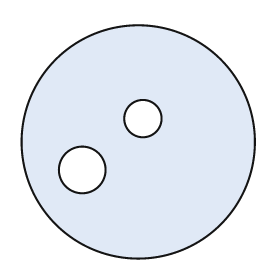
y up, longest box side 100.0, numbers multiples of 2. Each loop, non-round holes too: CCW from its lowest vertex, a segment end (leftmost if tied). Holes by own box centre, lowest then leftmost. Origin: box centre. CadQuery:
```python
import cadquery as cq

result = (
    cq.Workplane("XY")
    .moveTo(0.0, 0.0)
    .circle(50.0)
    .moveTo(-24.0, -12.0)
    .circle(10.0)
    .moveTo(2.0, 10.0)
    .circle(8.0)
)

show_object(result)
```